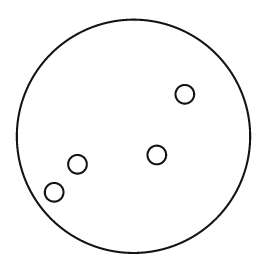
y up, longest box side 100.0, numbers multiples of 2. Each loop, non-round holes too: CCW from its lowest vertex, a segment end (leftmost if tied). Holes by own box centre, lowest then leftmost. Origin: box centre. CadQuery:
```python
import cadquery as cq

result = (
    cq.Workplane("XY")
    .moveTo(0.0, 0.0)
    .circle(50.0)
    .moveTo(-34.0, -24.0)
    .circle(4.0)
    .moveTo(-24.0, -12.0)
    .circle(4.0)
    .moveTo(10.0, -8.0)
    .circle(4.0)
    .moveTo(22.0, 18.0)
    .circle(4.0)
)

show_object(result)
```